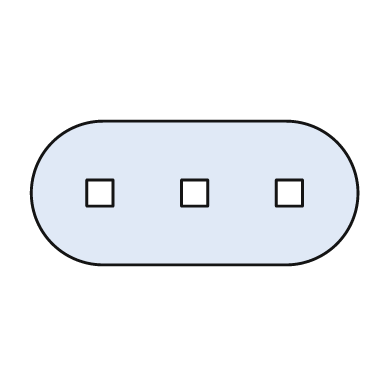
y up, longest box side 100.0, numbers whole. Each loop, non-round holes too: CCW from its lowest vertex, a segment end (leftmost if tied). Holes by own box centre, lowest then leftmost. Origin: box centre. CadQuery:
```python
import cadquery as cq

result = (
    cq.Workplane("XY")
    .moveTo(-28.0, -22.0)
    .lineTo(28.0, -22.0)
    .threePointArc((50.0, 0.0), (28.0, 22.0))
    .lineTo(-28.0, 22.0)
    .threePointArc((-50.0, 0.0), (-28.0, -22.0))
    .close()
    .moveTo(-33.0, -4.0)
    .lineTo(-25.0, -4.0)
    .lineTo(-25.0, 4.0)
    .lineTo(-33.0, 4.0)
    .close()
    .moveTo(-4.0, -4.0)
    .lineTo(4.0, -4.0)
    .lineTo(4.0, 4.0)
    .lineTo(-4.0, 4.0)
    .close()
    .moveTo(25.0, -4.0)
    .lineTo(33.0, -4.0)
    .lineTo(33.0, 4.0)
    .lineTo(25.0, 4.0)
    .close()
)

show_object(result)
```